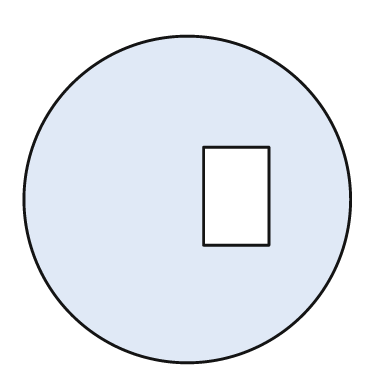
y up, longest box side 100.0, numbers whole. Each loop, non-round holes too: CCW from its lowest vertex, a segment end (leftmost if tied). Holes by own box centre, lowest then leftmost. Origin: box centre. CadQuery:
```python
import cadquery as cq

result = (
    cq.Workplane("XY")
    .moveTo(0.0, 0.0)
    .circle(50.0)
    .moveTo(5.0, -14.0)
    .lineTo(25.0, -14.0)
    .lineTo(25.0, 16.0)
    .lineTo(5.0, 16.0)
    .close()
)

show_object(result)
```